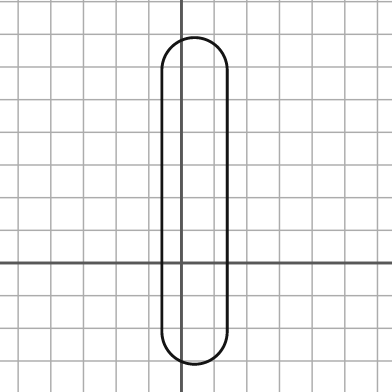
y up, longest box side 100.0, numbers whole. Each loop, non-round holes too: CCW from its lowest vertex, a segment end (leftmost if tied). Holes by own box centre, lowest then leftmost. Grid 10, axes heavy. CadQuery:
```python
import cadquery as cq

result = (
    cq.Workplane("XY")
    .moveTo(-6.0, -21.0)
    .threePointArc((4.0, -31.0), (14.0, -21.0))
    .lineTo(14.0, 59.0)
    .threePointArc((4.0, 69.0), (-6.0, 59.0))
    .close()
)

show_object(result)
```